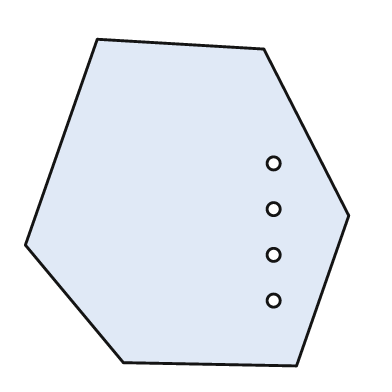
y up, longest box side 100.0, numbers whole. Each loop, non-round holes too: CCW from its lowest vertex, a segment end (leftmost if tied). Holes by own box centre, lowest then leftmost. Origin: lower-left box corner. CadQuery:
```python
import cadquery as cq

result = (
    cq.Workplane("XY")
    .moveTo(83.0, 0.0)
    .lineTo(99.0, 46.0)
    .lineTo(73.0, 97.0)
    .lineTo(22.0, 100.0)
    .lineTo(0.0, 37.0)
    .lineTo(30.0, 1.0)
    .close()
    .moveTo(76.0, 20.0)
    .circle(2.0)
    .moveTo(76.0, 34.0)
    .circle(2.0)
    .moveTo(76.0, 48.0)
    .circle(2.0)
    .moveTo(76.0, 62.0)
    .circle(2.0)
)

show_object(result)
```